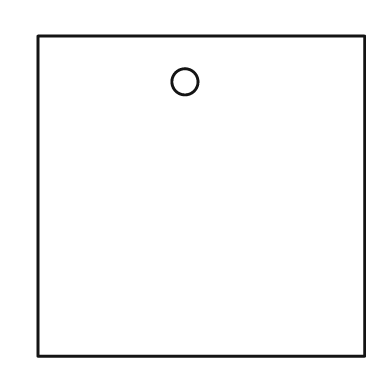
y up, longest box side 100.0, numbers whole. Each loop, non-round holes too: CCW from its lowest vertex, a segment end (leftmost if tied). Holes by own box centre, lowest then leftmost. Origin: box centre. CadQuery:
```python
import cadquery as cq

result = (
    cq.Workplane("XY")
    .moveTo(-50.0, -49.0)
    .lineTo(50.0, -49.0)
    .lineTo(50.0, 49.0)
    .lineTo(-50.0, 49.0)
    .close()
    .moveTo(-5.0, 35.0)
    .circle(4.0)
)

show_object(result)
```